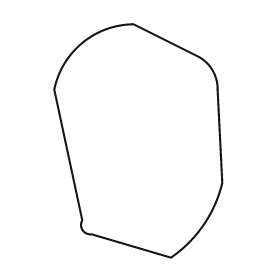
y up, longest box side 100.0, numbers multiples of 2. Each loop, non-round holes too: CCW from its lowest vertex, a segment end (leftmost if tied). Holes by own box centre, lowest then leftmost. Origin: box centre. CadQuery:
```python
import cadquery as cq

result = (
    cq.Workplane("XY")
    .moveTo(14.0, -50.0)
    .threePointArc((28.0, -36.0), (36.0, -18.0))
    .lineTo(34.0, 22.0)
    .threePointArc((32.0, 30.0), (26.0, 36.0))
    .lineTo(-2.0, 50.0)
    .threePointArc((-24.0, 42.0), (-36.0, 22.0))
    .lineTo(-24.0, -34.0)
    .threePointArc((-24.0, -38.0), (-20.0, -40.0))
    .close()
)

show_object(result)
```